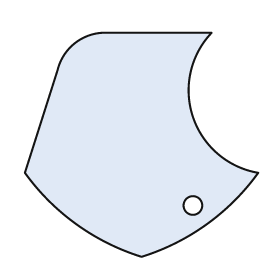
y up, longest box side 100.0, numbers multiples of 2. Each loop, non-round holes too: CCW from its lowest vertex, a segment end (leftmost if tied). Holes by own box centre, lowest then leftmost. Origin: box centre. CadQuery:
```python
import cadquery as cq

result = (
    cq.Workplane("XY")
    .moveTo(0.0, -48.0)
    .threePointArc((28.0, -34.0), (50.0, -12.0))
    .threePointArc((22.0, 12.0), (30.0, 48.0))
    .lineTo(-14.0, 48.0)
    .threePointArc((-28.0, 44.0), (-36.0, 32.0))
    .lineTo(-50.0, -12.0)
    .threePointArc((-28.0, -34.0), (0.0, -48.0))
    .close()
    .moveTo(22.0, -26.0)
    .circle(4.0)
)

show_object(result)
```